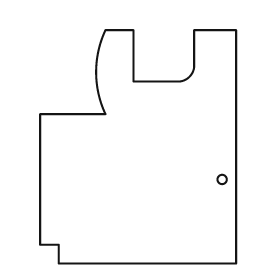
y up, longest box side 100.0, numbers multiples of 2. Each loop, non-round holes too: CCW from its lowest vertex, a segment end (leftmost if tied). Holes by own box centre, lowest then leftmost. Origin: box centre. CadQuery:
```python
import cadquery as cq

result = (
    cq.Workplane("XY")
    .moveTo(-34.0, -50.0)
    .lineTo(42.0, -50.0)
    .lineTo(42.0, 50.0)
    .lineTo(24.0, 50.0)
    .lineTo(24.0, 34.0)
    .threePointArc((22.0, 30.0), (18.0, 28.0))
    .lineTo(-2.0, 28.0)
    .lineTo(-2.0, 50.0)
    .lineTo(-14.0, 50.0)
    .threePointArc((-18.0, 32.0), (-14.0, 14.0))
    .lineTo(-42.0, 14.0)
    .lineTo(-42.0, -42.0)
    .lineTo(-34.0, -42.0)
    .close()
    .moveTo(36.0, -14.0)
    .circle(2.0)
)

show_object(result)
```